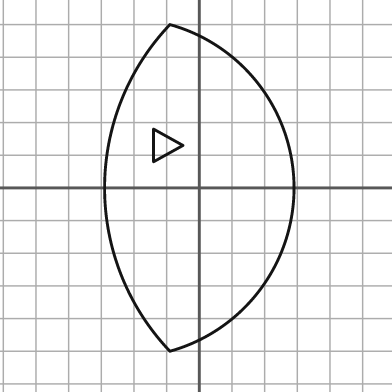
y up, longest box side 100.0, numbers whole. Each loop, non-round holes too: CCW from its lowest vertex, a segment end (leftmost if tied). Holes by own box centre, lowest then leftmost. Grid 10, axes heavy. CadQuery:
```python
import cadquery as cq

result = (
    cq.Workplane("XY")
    .moveTo(-9.0, -50.0)
    .threePointArc((29.0, 0.0), (-9.0, 50.0))
    .threePointArc((-29.0, 0.0), (-9.0, -50.0))
    .close()
    .moveTo(-14.0, 8.0)
    .lineTo(-5.0, 13.0)
    .lineTo(-14.0, 18.0)
    .close()
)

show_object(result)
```